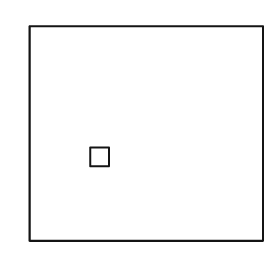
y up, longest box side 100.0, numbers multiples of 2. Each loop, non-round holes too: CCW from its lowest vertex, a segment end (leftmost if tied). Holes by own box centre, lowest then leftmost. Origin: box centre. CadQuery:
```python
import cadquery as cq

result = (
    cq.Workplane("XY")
    .moveTo(-50.0, -46.0)
    .lineTo(50.0, -46.0)
    .lineTo(50.0, 46.0)
    .lineTo(-50.0, 46.0)
    .close()
    .moveTo(-24.0, -14.0)
    .lineTo(-16.0, -14.0)
    .lineTo(-16.0, -6.0)
    .lineTo(-24.0, -6.0)
    .close()
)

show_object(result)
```